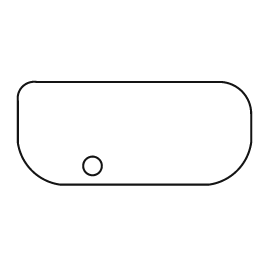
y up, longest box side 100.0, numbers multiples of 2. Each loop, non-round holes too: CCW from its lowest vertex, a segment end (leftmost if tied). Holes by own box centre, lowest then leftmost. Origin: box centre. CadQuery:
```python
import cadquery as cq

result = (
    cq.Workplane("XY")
    .moveTo(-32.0, -22.0)
    .lineTo(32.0, -22.0)
    .threePointArc((44.0, -16.0), (50.0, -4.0))
    .lineTo(50.0, 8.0)
    .threePointArc((46.0, 18.0), (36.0, 22.0))
    .lineTo(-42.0, 22.0)
    .threePointArc((-48.0, 20.0), (-50.0, 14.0))
    .lineTo(-50.0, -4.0)
    .threePointArc((-44.0, -16.0), (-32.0, -22.0))
    .close()
    .moveTo(-18.0, -14.0)
    .circle(4.0)
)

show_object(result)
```